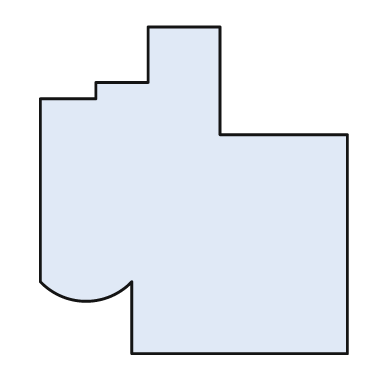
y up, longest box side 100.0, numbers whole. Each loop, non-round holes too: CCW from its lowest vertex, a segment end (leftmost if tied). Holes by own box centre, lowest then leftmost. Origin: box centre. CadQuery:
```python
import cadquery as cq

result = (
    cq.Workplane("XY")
    .moveTo(-19.0, -50.0)
    .lineTo(47.0, -50.0)
    .lineTo(47.0, 17.0)
    .lineTo(8.0, 17.0)
    .lineTo(8.0, 50.0)
    .lineTo(-14.0, 50.0)
    .lineTo(-14.0, 33.0)
    .lineTo(-30.0, 33.0)
    .lineTo(-30.0, 28.0)
    .lineTo(-47.0, 28.0)
    .lineTo(-47.0, -28.0)
    .threePointArc((-33.0, -34.0), (-19.0, -28.0))
    .close()
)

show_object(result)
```